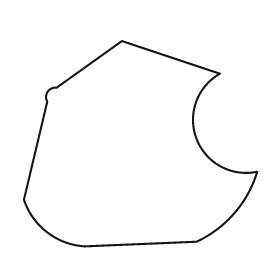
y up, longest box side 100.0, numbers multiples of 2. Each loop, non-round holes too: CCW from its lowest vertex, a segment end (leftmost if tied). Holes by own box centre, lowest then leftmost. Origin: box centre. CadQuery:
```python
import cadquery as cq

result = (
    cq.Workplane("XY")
    .moveTo(-24.0, -44.0)
    .lineTo(24.0, -42.0)
    .threePointArc((40.0, -30.0), (50.0, -12.0))
    .threePointArc((24.0, 2.0), (34.0, 30.0))
    .lineTo(-8.0, 44.0)
    .lineTo(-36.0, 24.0)
    .threePointArc((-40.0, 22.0), (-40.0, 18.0))
    .lineTo(-50.0, -24.0)
    .threePointArc((-40.0, -38.0), (-24.0, -44.0))
    .close()
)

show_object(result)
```